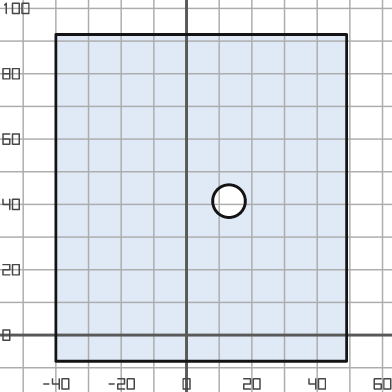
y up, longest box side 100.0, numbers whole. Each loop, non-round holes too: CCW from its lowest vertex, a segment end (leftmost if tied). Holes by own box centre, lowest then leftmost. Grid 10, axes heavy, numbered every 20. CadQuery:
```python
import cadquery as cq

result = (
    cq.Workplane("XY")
    .moveTo(-40.0, -8.0)
    .lineTo(49.0, -8.0)
    .lineTo(49.0, 92.0)
    .lineTo(-40.0, 92.0)
    .close()
    .moveTo(13.0, 41.0)
    .circle(5.0)
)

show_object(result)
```